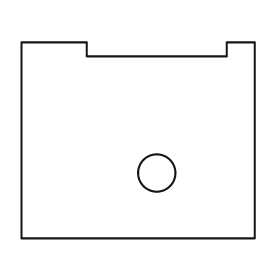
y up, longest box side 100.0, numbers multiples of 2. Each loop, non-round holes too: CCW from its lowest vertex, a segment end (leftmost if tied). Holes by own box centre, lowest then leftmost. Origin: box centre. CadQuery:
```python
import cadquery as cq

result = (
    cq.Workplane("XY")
    .moveTo(-50.0, -42.0)
    .lineTo(50.0, -42.0)
    .lineTo(50.0, 42.0)
    .lineTo(38.0, 42.0)
    .lineTo(38.0, 36.0)
    .lineTo(-22.0, 36.0)
    .lineTo(-22.0, 42.0)
    .lineTo(-50.0, 42.0)
    .close()
    .moveTo(8.0, -14.0)
    .circle(8.0)
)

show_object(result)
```